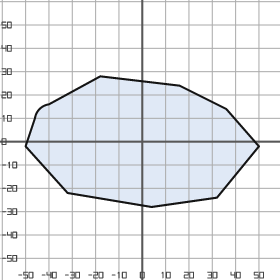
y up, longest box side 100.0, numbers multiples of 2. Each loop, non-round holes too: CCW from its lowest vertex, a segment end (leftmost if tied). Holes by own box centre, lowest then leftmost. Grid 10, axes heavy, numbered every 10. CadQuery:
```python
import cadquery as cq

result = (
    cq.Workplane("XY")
    .moveTo(4.0, -28.0)
    .lineTo(32.0, -24.0)
    .lineTo(50.0, -2.0)
    .lineTo(36.0, 14.0)
    .lineTo(16.0, 24.0)
    .lineTo(-18.0, 28.0)
    .lineTo(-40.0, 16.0)
    .threePointArc((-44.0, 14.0), (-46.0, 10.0))
    .lineTo(-50.0, -2.0)
    .lineTo(-32.0, -22.0)
    .close()
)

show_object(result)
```